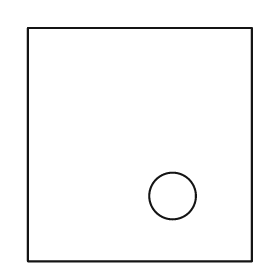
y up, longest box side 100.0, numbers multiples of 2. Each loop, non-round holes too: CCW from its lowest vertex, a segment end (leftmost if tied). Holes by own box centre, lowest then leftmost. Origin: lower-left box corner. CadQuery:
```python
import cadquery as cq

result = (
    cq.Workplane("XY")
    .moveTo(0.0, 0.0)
    .lineTo(96.0, 0.0)
    .lineTo(96.0, 100.0)
    .lineTo(0.0, 100.0)
    .close()
    .moveTo(62.0, 28.0)
    .circle(10.0)
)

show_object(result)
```